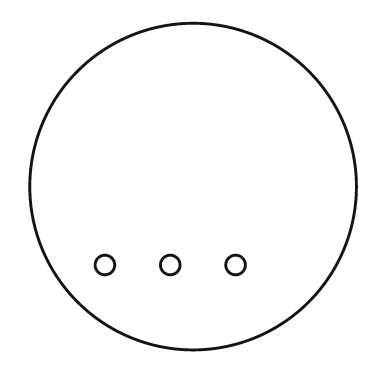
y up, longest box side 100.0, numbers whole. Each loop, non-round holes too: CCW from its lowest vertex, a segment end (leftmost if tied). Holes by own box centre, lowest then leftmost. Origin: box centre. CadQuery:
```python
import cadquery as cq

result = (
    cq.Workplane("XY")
    .moveTo(0.0, 0.0)
    .circle(50.0)
    .moveTo(-27.0, -24.0)
    .circle(3.0)
    .moveTo(-7.0, -24.0)
    .circle(3.0)
    .moveTo(13.0, -24.0)
    .circle(3.0)
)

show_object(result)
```